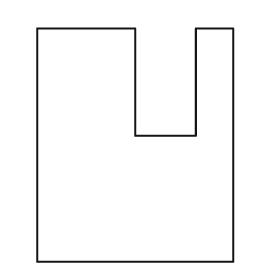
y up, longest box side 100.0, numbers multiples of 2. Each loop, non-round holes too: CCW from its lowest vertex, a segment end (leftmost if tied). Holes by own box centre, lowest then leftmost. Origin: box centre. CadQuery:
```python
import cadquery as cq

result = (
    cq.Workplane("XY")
    .moveTo(-42.0, -50.0)
    .lineTo(42.0, -50.0)
    .lineTo(42.0, 50.0)
    .lineTo(26.0, 50.0)
    .lineTo(26.0, 4.0)
    .lineTo(0.0, 4.0)
    .lineTo(0.0, 50.0)
    .lineTo(-42.0, 50.0)
    .close()
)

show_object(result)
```